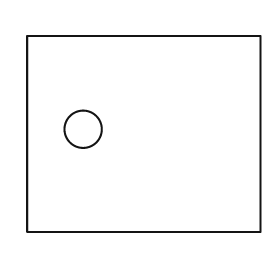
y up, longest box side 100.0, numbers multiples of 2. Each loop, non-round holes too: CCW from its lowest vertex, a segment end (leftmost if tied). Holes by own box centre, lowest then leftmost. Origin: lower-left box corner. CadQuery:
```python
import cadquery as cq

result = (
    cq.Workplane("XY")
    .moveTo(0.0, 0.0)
    .lineTo(100.0, 0.0)
    .lineTo(100.0, 84.0)
    .lineTo(0.0, 84.0)
    .close()
    .moveTo(24.0, 44.0)
    .circle(8.0)
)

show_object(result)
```